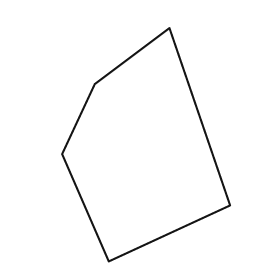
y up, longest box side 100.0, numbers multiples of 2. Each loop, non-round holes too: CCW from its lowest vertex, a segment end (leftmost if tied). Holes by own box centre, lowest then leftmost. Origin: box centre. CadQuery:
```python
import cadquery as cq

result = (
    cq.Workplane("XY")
    .moveTo(-16.0, -50.0)
    .lineTo(36.0, -26.0)
    .lineTo(10.0, 50.0)
    .lineTo(-22.0, 26.0)
    .lineTo(-36.0, -4.0)
    .close()
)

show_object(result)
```